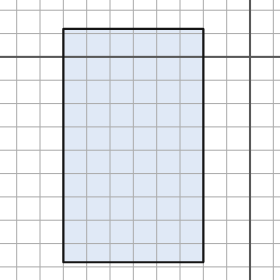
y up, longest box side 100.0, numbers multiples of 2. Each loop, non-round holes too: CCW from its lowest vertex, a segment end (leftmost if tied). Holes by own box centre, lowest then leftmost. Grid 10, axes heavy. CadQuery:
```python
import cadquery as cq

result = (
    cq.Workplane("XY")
    .moveTo(-80.0, -88.0)
    .lineTo(-20.0, -88.0)
    .lineTo(-20.0, 12.0)
    .lineTo(-80.0, 12.0)
    .close()
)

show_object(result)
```